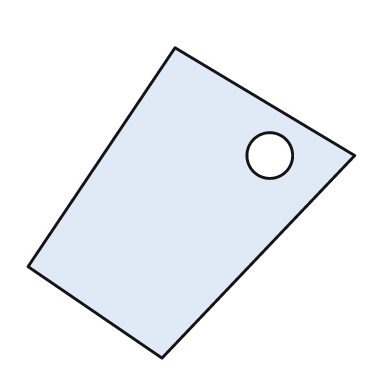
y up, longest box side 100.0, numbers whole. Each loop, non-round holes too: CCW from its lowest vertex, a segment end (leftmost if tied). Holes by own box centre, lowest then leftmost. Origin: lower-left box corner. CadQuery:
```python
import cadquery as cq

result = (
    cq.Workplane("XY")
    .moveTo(41.0, 0.0)
    .lineTo(100.0, 62.0)
    .lineTo(45.0, 95.0)
    .lineTo(0.0, 28.0)
    .close()
    .moveTo(74.0, 62.0)
    .circle(7.0)
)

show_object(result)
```